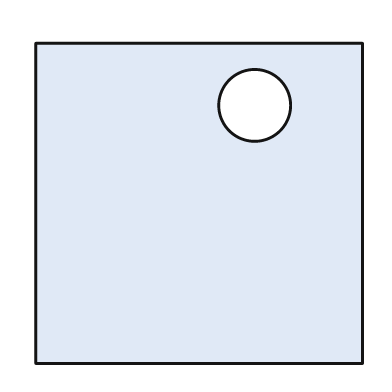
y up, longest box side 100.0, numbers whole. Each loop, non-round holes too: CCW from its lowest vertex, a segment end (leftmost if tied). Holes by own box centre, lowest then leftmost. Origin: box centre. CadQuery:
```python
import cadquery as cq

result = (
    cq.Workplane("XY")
    .moveTo(-50.0, -49.0)
    .lineTo(50.0, -49.0)
    .lineTo(50.0, 49.0)
    .lineTo(-50.0, 49.0)
    .close()
    .moveTo(17.0, 30.0)
    .circle(11.0)
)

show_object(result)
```